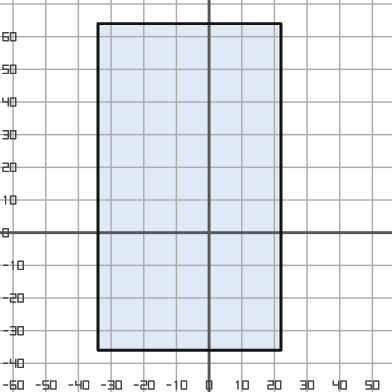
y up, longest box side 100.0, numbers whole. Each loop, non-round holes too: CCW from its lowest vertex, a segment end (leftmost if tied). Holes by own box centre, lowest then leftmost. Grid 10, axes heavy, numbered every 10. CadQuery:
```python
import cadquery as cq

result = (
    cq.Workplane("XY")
    .moveTo(-34.0, -36.0)
    .lineTo(22.0, -36.0)
    .lineTo(22.0, 64.0)
    .lineTo(-34.0, 64.0)
    .close()
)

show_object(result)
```